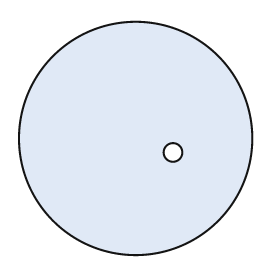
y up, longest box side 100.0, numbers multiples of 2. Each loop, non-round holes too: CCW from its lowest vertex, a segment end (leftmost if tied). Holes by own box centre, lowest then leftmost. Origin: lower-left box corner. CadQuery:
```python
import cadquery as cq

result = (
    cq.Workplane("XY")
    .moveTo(50.0, 50.0)
    .circle(50.0)
    .moveTo(66.0, 44.0)
    .circle(4.0)
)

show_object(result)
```